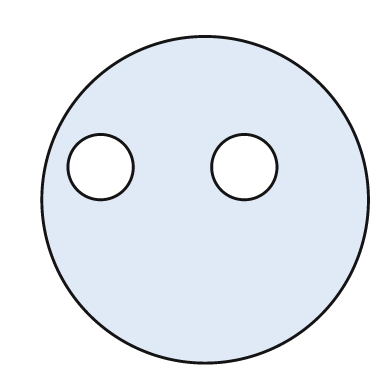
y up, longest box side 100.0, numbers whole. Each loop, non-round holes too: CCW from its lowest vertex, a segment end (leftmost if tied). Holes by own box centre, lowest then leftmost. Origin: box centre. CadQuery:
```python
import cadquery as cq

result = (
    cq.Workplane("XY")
    .moveTo(0.0, 0.0)
    .circle(50.0)
    .moveTo(-32.0, 10.0)
    .circle(10.0)
    .moveTo(12.0, 10.0)
    .circle(10.0)
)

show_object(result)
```